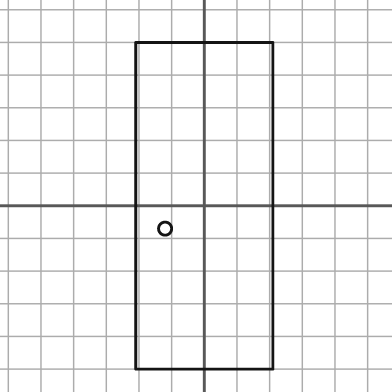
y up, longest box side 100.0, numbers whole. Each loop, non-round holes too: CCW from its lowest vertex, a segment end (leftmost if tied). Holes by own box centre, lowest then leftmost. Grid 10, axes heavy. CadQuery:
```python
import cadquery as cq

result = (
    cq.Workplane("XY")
    .moveTo(-21.0, -50.0)
    .lineTo(21.0, -50.0)
    .lineTo(21.0, 50.0)
    .lineTo(-21.0, 50.0)
    .close()
    .moveTo(-12.0, -7.0)
    .circle(2.0)
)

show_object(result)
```